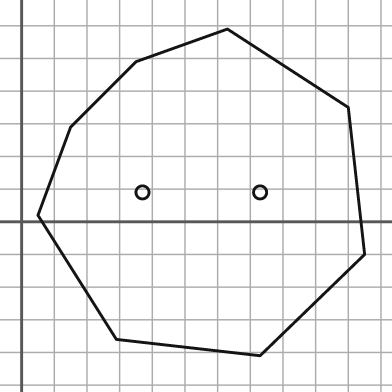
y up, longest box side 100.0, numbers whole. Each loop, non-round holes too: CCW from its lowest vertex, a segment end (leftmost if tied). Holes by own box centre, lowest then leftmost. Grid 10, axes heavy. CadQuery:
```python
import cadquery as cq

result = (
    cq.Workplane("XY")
    .moveTo(73.0, -41.0)
    .lineTo(105.0, -10.0)
    .lineTo(100.0, 35.0)
    .lineTo(63.0, 59.0)
    .lineTo(35.0, 49.0)
    .lineTo(15.0, 29.0)
    .lineTo(5.0, 2.0)
    .lineTo(29.0, -36.0)
    .close()
    .moveTo(37.0, 9.0)
    .circle(2.0)
    .moveTo(73.0, 9.0)
    .circle(2.0)
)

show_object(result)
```